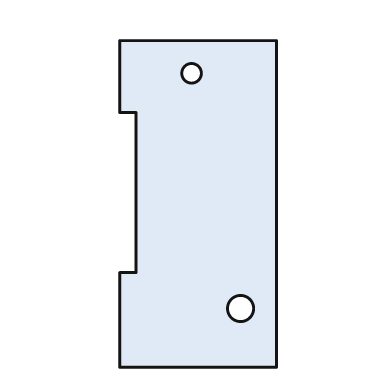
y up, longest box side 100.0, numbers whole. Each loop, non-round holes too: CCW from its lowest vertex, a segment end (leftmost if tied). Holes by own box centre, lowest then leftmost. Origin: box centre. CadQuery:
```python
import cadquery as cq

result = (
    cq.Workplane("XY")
    .moveTo(-24.0, -50.0)
    .lineTo(24.0, -50.0)
    .lineTo(24.0, 50.0)
    .lineTo(-24.0, 50.0)
    .lineTo(-24.0, 28.0)
    .lineTo(-19.0, 28.0)
    .lineTo(-19.0, -21.0)
    .lineTo(-24.0, -21.0)
    .close()
    .moveTo(13.0, -32.0)
    .circle(4.0)
    .moveTo(-2.0, 40.0)
    .circle(3.0)
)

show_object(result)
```